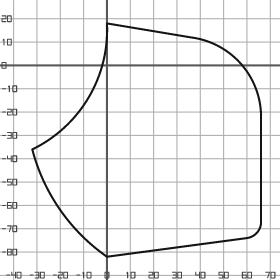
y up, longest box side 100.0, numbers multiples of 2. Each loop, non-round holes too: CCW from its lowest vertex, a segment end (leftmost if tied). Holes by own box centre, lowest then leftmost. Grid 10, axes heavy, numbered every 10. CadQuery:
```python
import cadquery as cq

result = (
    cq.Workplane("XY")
    .moveTo(0.0, -82.0)
    .lineTo(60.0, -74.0)
    .threePointArc((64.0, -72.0), (66.0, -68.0))
    .lineTo(66.0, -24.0)
    .threePointArc((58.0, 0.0), (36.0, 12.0))
    .lineTo(0.0, 18.0)
    .threePointArc((-8.0, -14.0), (-32.0, -36.0))
    .threePointArc((-20.0, -62.0), (0.0, -82.0))
    .close()
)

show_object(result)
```